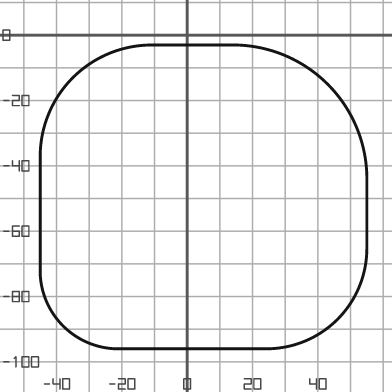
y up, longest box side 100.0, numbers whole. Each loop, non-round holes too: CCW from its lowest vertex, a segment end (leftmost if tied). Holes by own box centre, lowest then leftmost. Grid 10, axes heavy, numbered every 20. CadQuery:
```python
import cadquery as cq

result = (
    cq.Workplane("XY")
    .moveTo(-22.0, -96.0)
    .lineTo(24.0, -96.0)
    .threePointArc((46.0, -87.0), (55.0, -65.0))
    .lineTo(55.0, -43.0)
    .threePointArc((43.0, -15.0), (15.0, -3.0))
    .lineTo(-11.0, -3.0)
    .threePointArc((-35.0, -13.0), (-45.0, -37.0))
    .lineTo(-45.0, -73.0)
    .threePointArc((-38.0, -89.0), (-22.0, -96.0))
    .close()
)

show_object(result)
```